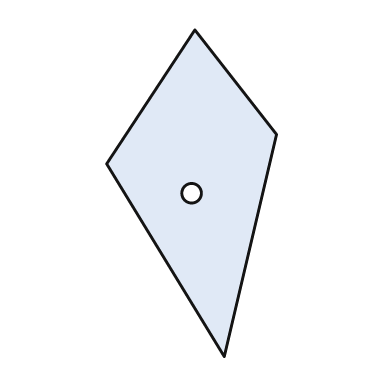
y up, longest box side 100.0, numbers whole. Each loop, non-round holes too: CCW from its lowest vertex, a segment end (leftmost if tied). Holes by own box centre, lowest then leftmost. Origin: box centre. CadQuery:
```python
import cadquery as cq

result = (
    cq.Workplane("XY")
    .moveTo(10.0, -50.0)
    .lineTo(26.0, 18.0)
    .lineTo(1.0, 50.0)
    .lineTo(-26.0, 9.0)
    .close()
    .moveTo(0.0, 0.0)
    .circle(3.0)
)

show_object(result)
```